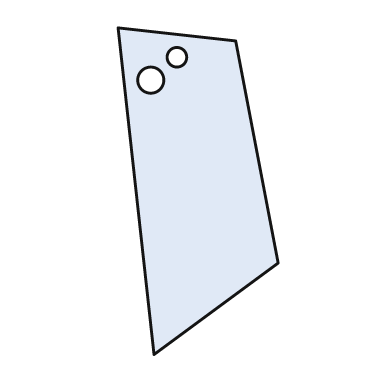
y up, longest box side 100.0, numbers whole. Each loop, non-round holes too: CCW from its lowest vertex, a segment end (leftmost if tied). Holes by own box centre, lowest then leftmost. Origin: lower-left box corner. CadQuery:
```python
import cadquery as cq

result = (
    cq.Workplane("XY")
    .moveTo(11.0, 0.0)
    .lineTo(49.0, 28.0)
    .lineTo(36.0, 96.0)
    .lineTo(0.0, 100.0)
    .close()
    .moveTo(10.0, 84.0)
    .circle(4.0)
    .moveTo(18.0, 91.0)
    .circle(3.0)
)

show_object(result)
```